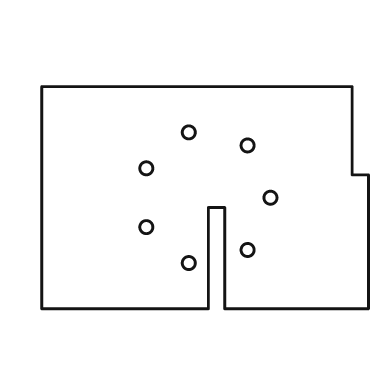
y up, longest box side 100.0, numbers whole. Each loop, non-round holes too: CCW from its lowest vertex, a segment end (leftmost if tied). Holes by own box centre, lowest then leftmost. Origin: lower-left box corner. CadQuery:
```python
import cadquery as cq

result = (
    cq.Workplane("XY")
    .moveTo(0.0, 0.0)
    .lineTo(51.0, 0.0)
    .lineTo(51.0, 31.0)
    .lineTo(56.0, 31.0)
    .lineTo(56.0, 0.0)
    .lineTo(100.0, 0.0)
    .lineTo(100.0, 41.0)
    .lineTo(95.0, 41.0)
    .lineTo(95.0, 68.0)
    .lineTo(0.0, 68.0)
    .close()
    .moveTo(45.0, 14.0)
    .circle(2.0)
    .moveTo(63.0, 18.0)
    .circle(2.0)
    .moveTo(32.0, 25.0)
    .circle(2.0)
    .moveTo(70.0, 34.0)
    .circle(2.0)
    .moveTo(32.0, 43.0)
    .circle(2.0)
    .moveTo(63.0, 50.0)
    .circle(2.0)
    .moveTo(45.0, 54.0)
    .circle(2.0)
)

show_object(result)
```